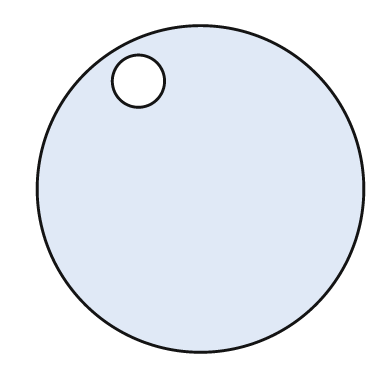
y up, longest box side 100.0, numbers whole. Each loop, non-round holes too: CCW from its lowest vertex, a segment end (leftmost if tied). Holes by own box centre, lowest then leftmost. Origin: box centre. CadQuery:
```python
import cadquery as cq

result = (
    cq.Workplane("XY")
    .moveTo(0.0, 0.0)
    .circle(50.0)
    .moveTo(-19.0, 33.0)
    .circle(8.0)
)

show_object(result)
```